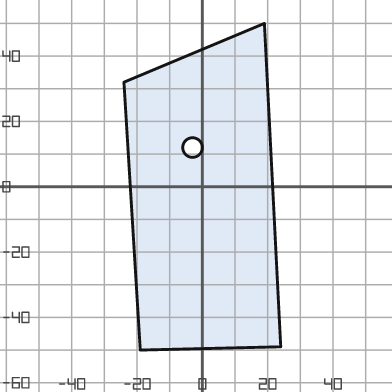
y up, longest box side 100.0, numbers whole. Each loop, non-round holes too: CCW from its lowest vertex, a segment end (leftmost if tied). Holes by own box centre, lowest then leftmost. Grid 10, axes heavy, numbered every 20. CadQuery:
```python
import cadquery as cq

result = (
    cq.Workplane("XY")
    .moveTo(-19.0, -50.0)
    .lineTo(24.0, -49.0)
    .lineTo(19.0, 50.0)
    .lineTo(-24.0, 32.0)
    .close()
    .moveTo(-3.0, 12.0)
    .circle(3.0)
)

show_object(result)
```